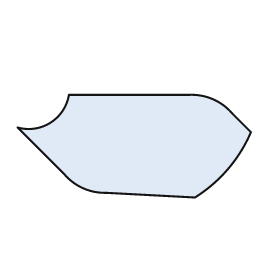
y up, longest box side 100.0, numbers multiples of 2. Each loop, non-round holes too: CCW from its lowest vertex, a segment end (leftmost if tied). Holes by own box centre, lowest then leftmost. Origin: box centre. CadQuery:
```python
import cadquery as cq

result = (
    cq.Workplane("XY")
    .moveTo(26.0, -22.0)
    .threePointArc((40.0, -10.0), (50.0, 6.0))
    .lineTo(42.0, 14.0)
    .threePointArc((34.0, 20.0), (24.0, 22.0))
    .lineTo(-28.0, 22.0)
    .threePointArc((-36.0, 10.0), (-50.0, 8.0))
    .lineTo(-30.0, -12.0)
    .threePointArc((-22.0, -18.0), (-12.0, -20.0))
    .close()
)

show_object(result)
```